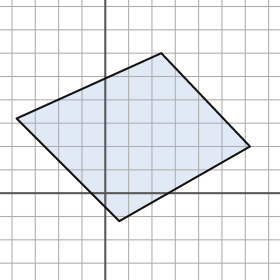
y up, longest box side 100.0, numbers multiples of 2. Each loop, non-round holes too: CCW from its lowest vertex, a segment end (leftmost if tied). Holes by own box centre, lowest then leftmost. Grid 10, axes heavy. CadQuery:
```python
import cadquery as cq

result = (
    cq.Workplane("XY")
    .moveTo(6.0, -12.0)
    .lineTo(62.0, 20.0)
    .lineTo(24.0, 60.0)
    .lineTo(-38.0, 32.0)
    .close()
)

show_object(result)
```